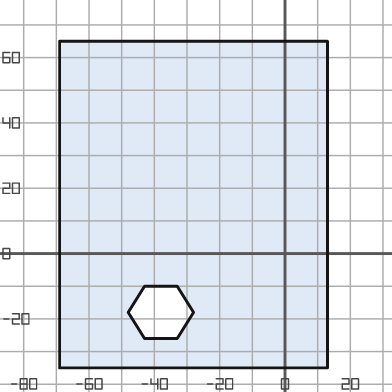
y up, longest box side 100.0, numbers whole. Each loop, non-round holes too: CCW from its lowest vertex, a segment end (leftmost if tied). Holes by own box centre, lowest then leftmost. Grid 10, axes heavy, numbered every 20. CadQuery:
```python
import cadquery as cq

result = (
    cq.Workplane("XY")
    .moveTo(-69.0, -35.0)
    .lineTo(13.0, -35.0)
    .lineTo(13.0, 65.0)
    .lineTo(-69.0, 65.0)
    .close()
    .moveTo(-43.0, -26.0)
    .lineTo(-33.0, -26.0)
    .lineTo(-28.0, -18.0)
    .lineTo(-33.0, -10.0)
    .lineTo(-43.0, -10.0)
    .lineTo(-48.0, -18.0)
    .close()
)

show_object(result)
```